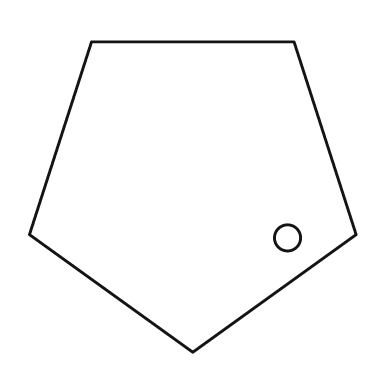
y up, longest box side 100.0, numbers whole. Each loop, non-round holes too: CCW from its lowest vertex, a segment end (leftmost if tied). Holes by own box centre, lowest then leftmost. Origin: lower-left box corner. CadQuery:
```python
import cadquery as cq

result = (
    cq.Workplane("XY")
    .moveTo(50.0, 0.0)
    .lineTo(100.0, 36.0)
    .lineTo(81.0, 95.0)
    .lineTo(19.0, 95.0)
    .lineTo(0.0, 36.0)
    .close()
    .moveTo(79.0, 35.0)
    .circle(4.0)
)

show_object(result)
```